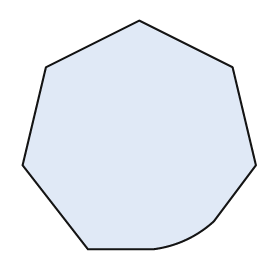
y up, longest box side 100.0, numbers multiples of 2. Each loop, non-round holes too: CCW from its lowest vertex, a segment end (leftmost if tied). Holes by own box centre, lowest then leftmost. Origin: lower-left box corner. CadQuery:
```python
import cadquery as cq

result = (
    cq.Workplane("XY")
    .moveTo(28.0, 0.0)
    .lineTo(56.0, 0.0)
    .threePointArc((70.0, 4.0), (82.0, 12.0))
    .lineTo(100.0, 36.0)
    .lineTo(90.0, 78.0)
    .lineTo(50.0, 98.0)
    .lineTo(10.0, 78.0)
    .lineTo(0.0, 36.0)
    .close()
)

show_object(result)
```